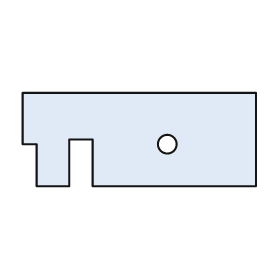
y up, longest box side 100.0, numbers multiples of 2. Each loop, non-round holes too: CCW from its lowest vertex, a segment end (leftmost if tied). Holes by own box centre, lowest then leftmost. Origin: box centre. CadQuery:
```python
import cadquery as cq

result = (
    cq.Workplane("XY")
    .moveTo(-44.0, -20.0)
    .lineTo(-30.0, -20.0)
    .lineTo(-30.0, 0.0)
    .lineTo(-20.0, 0.0)
    .lineTo(-20.0, -20.0)
    .lineTo(50.0, -20.0)
    .lineTo(50.0, 20.0)
    .lineTo(-50.0, 20.0)
    .lineTo(-50.0, -2.0)
    .lineTo(-44.0, -2.0)
    .close()
    .moveTo(12.0, -2.0)
    .circle(4.0)
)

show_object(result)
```